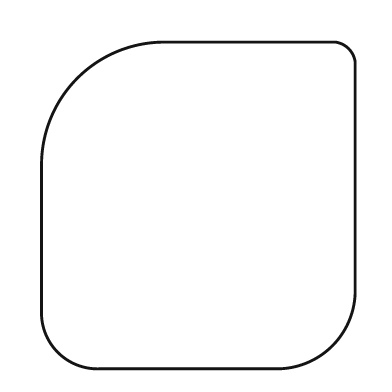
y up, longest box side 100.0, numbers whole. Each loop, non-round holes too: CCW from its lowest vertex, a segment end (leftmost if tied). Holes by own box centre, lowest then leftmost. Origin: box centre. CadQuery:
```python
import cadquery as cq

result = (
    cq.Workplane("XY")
    .moveTo(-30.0, -50.0)
    .lineTo(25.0, -50.0)
    .threePointArc((41.0, -43.0), (48.0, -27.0))
    .lineTo(48.0, 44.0)
    .threePointArc((46.0, 48.0), (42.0, 50.0))
    .lineTo(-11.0, 50.0)
    .threePointArc((-37.0, 39.0), (-48.0, 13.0))
    .lineTo(-48.0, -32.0)
    .threePointArc((-43.0, -45.0), (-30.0, -50.0))
    .close()
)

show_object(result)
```